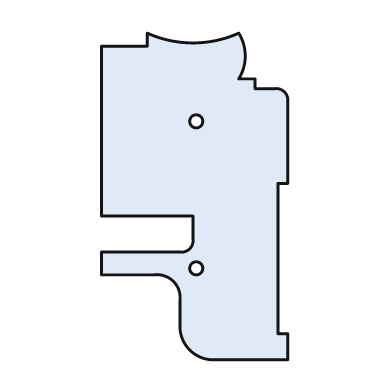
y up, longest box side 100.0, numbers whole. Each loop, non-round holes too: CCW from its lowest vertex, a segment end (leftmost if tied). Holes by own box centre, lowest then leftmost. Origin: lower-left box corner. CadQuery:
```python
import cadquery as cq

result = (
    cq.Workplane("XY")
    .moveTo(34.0, 0.0)
    .lineTo(57.0, 0.0)
    .lineTo(57.0, 8.0)
    .lineTo(54.0, 8.0)
    .lineTo(54.0, 54.0)
    .lineTo(57.0, 54.0)
    .lineTo(57.0, 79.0)
    .threePointArc((56.0, 82.0), (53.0, 83.0))
    .lineTo(47.0, 83.0)
    .lineTo(47.0, 86.0)
    .lineTo(42.0, 86.0)
    .threePointArc((44.0, 93.0), (42.0, 100.0))
    .threePointArc((28.0, 97.0), (14.0, 100.0))
    .lineTo(14.0, 96.0)
    .lineTo(0.0, 96.0)
    .lineTo(0.0, 44.0)
    .lineTo(28.0, 44.0)
    .lineTo(28.0, 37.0)
    .threePointArc((27.0, 34.0), (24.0, 33.0))
    .lineTo(0.0, 33.0)
    .lineTo(0.0, 26.0)
    .lineTo(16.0, 26.0)
    .threePointArc((22.0, 24.0), (24.0, 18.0))
    .lineTo(24.0, 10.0)
    .threePointArc((27.0, 3.0), (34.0, 0.0))
    .close()
    .moveTo(29.0, 28.0)
    .circle(2.0)
    .moveTo(29.0, 73.0)
    .circle(2.0)
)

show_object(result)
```